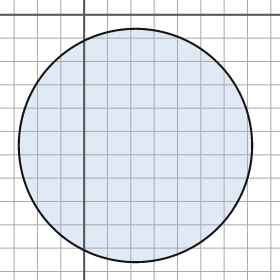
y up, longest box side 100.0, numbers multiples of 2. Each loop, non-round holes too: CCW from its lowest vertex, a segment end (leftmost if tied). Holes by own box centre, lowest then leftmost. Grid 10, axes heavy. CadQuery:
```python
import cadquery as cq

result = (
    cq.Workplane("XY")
    .moveTo(22.0, -56.0)
    .circle(50.0)
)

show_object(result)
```